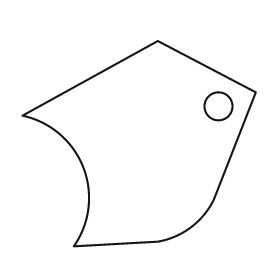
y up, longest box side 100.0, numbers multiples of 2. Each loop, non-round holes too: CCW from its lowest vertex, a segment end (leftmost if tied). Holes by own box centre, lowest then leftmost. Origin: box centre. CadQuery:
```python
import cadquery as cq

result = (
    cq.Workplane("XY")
    .moveTo(-28.0, -44.0)
    .lineTo(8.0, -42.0)
    .threePointArc((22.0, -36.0), (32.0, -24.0))
    .lineTo(50.0, 22.0)
    .lineTo(8.0, 44.0)
    .lineTo(-50.0, 12.0)
    .threePointArc((-24.0, -10.0), (-28.0, -44.0))
    .close()
    .moveTo(34.0, 16.0)
    .circle(6.0)
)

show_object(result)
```